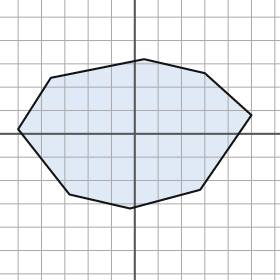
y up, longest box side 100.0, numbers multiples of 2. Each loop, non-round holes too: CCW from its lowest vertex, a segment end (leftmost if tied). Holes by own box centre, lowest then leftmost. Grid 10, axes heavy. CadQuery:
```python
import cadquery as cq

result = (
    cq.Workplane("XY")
    .moveTo(-2.0, -32.0)
    .lineTo(28.0, -24.0)
    .lineTo(50.0, 8.0)
    .lineTo(30.0, 26.0)
    .lineTo(4.0, 32.0)
    .lineTo(-36.0, 24.0)
    .lineTo(-50.0, 2.0)
    .lineTo(-28.0, -26.0)
    .close()
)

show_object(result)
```